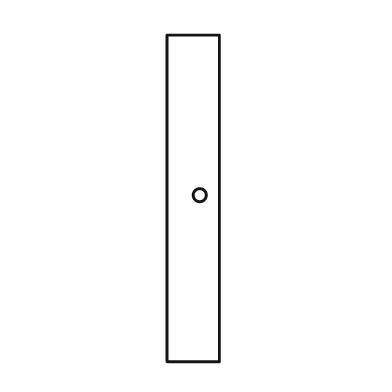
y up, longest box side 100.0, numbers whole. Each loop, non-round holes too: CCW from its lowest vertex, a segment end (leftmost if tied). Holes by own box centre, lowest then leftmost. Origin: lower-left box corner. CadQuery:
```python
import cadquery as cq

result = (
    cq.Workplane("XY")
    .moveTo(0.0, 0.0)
    .lineTo(16.0, 0.0)
    .lineTo(16.0, 100.0)
    .lineTo(0.0, 100.0)
    .close()
    .moveTo(10.0, 51.0)
    .circle(2.0)
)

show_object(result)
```